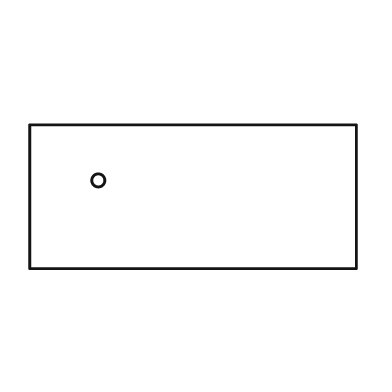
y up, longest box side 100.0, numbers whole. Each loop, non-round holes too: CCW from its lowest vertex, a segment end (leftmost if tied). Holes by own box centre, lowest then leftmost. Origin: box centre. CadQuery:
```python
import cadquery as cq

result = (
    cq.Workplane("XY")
    .moveTo(-50.0, -22.0)
    .lineTo(50.0, -22.0)
    .lineTo(50.0, 22.0)
    .lineTo(-50.0, 22.0)
    .close()
    .moveTo(-29.0, 5.0)
    .circle(2.0)
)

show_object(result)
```